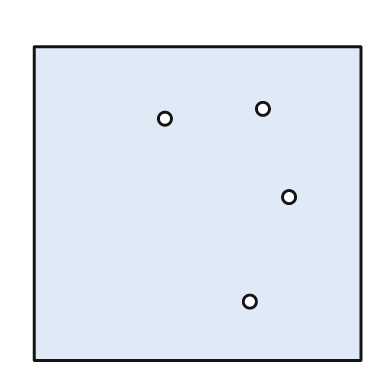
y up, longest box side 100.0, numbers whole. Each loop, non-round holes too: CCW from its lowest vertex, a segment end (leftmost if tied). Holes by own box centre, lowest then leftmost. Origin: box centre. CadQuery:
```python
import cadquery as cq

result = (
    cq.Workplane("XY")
    .moveTo(-50.0, -48.0)
    .lineTo(50.0, -48.0)
    .lineTo(50.0, 48.0)
    .lineTo(-50.0, 48.0)
    .close()
    .moveTo(16.0, -30.0)
    .circle(2.0)
    .moveTo(28.0, 2.0)
    .circle(2.0)
    .moveTo(-10.0, 26.0)
    .circle(2.0)
    .moveTo(20.0, 29.0)
    .circle(2.0)
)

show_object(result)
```